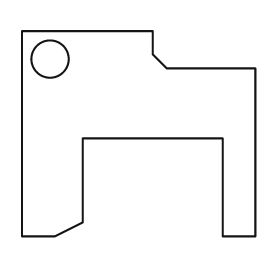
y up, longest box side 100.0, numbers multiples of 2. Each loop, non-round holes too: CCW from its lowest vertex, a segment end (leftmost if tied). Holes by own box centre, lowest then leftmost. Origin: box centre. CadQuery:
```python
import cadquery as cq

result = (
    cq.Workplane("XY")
    .moveTo(-50.0, -44.0)
    .lineTo(-36.0, -44.0)
    .lineTo(-24.0, -38.0)
    .lineTo(-24.0, -2.0)
    .lineTo(36.0, -2.0)
    .lineTo(36.0, -44.0)
    .lineTo(50.0, -44.0)
    .lineTo(50.0, 28.0)
    .lineTo(12.0, 28.0)
    .lineTo(6.0, 34.0)
    .lineTo(6.0, 44.0)
    .lineTo(-50.0, 44.0)
    .close()
    .moveTo(-38.0, 32.0)
    .circle(8.0)
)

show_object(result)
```